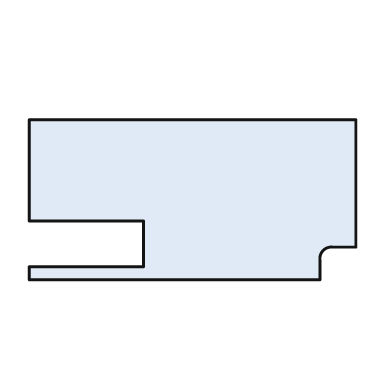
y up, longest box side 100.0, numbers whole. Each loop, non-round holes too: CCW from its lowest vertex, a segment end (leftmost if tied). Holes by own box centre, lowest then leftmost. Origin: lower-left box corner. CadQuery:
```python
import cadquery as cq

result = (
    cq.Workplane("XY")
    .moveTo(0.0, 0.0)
    .lineTo(89.0, 0.0)
    .lineTo(89.0, 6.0)
    .threePointArc((90.0, 9.0), (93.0, 10.0))
    .lineTo(100.0, 10.0)
    .lineTo(100.0, 49.0)
    .lineTo(0.0, 49.0)
    .lineTo(0.0, 18.0)
    .lineTo(35.0, 18.0)
    .lineTo(35.0, 4.0)
    .lineTo(0.0, 4.0)
    .close()
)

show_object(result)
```